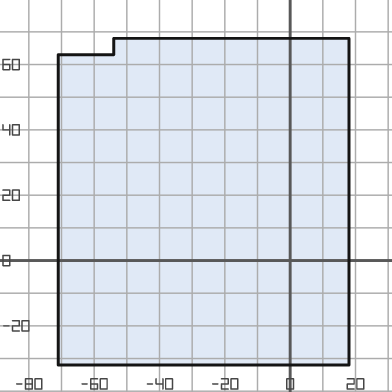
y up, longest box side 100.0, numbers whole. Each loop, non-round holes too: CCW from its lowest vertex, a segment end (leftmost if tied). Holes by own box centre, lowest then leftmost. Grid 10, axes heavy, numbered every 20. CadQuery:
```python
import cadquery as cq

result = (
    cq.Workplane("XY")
    .moveTo(-71.0, -32.0)
    .lineTo(18.0, -32.0)
    .lineTo(18.0, 68.0)
    .lineTo(-54.0, 68.0)
    .lineTo(-54.0, 63.0)
    .lineTo(-71.0, 63.0)
    .close()
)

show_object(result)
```